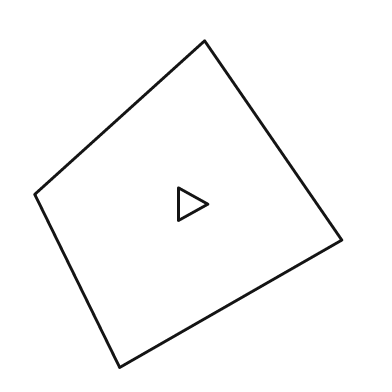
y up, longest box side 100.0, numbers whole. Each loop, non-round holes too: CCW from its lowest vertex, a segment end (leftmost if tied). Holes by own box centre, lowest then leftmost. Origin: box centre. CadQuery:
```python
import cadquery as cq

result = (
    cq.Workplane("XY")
    .moveTo(-21.0, -50.0)
    .lineTo(47.0, -11.0)
    .lineTo(5.0, 50.0)
    .lineTo(-47.0, 3.0)
    .close()
    .moveTo(-3.0, -5.0)
    .lineTo(6.0, 0.0)
    .lineTo(-3.0, 5.0)
    .close()
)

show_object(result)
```